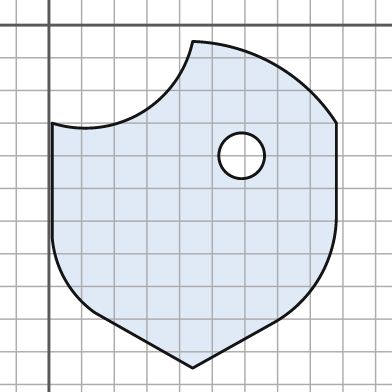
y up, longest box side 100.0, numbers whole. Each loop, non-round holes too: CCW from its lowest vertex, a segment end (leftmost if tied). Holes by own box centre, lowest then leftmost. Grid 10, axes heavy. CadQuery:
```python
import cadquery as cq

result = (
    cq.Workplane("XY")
    .moveTo(44.0, -105.0)
    .lineTo(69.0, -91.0)
    .threePointArc((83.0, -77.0), (88.0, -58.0))
    .lineTo(88.0, -30.0)
    .threePointArc((69.0, -12.0), (44.0, -5.0))
    .threePointArc((28.0, -27.0), (1.0, -30.0))
    .lineTo(1.0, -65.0)
    .threePointArc((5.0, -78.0), (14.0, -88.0))
    .close()
    .moveTo(59.0, -40.0)
    .circle(7.0)
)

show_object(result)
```